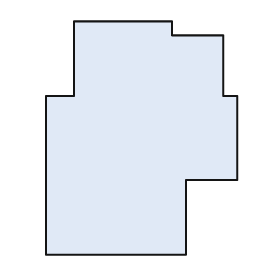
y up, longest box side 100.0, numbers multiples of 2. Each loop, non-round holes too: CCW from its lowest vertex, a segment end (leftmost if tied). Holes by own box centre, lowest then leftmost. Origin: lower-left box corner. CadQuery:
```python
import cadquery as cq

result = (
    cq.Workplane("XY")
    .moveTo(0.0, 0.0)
    .lineTo(60.0, 0.0)
    .lineTo(60.0, 32.0)
    .lineTo(82.0, 32.0)
    .lineTo(82.0, 68.0)
    .lineTo(76.0, 68.0)
    .lineTo(76.0, 94.0)
    .lineTo(54.0, 94.0)
    .lineTo(54.0, 100.0)
    .lineTo(12.0, 100.0)
    .lineTo(12.0, 68.0)
    .lineTo(0.0, 68.0)
    .close()
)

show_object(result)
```